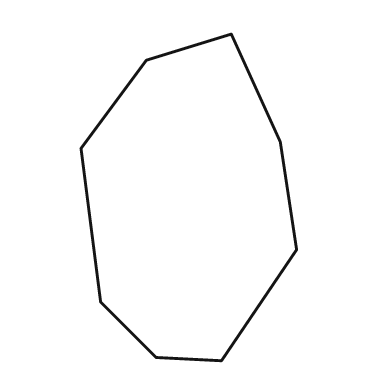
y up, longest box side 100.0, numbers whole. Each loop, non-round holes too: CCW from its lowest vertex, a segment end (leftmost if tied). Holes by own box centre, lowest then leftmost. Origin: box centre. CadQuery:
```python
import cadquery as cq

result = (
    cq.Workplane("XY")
    .moveTo(10.0, -50.0)
    .lineTo(33.0, -16.0)
    .lineTo(28.0, 17.0)
    .lineTo(13.0, 50.0)
    .lineTo(-13.0, 42.0)
    .lineTo(-33.0, 15.0)
    .lineTo(-27.0, -32.0)
    .lineTo(-10.0, -49.0)
    .close()
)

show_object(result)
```